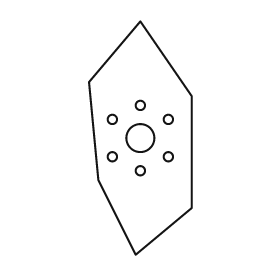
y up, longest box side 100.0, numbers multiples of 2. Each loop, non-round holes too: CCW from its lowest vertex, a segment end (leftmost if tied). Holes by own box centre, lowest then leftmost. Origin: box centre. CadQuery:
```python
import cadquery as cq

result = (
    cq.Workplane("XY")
    .moveTo(-2.0, -50.0)
    .lineTo(22.0, -30.0)
    .lineTo(22.0, 18.0)
    .lineTo(0.0, 50.0)
    .lineTo(-22.0, 24.0)
    .lineTo(-18.0, -18.0)
    .close()
    .moveTo(0.0, -14.0)
    .circle(2.0)
    .moveTo(-12.0, -8.0)
    .circle(2.0)
    .moveTo(12.0, -8.0)
    .circle(2.0)
    .moveTo(0.0, 0.0)
    .circle(6.0)
    .moveTo(-12.0, 8.0)
    .circle(2.0)
    .moveTo(12.0, 8.0)
    .circle(2.0)
    .moveTo(0.0, 14.0)
    .circle(2.0)
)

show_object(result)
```